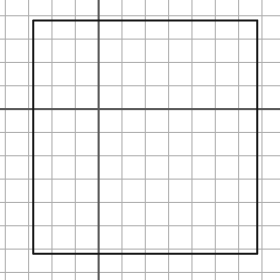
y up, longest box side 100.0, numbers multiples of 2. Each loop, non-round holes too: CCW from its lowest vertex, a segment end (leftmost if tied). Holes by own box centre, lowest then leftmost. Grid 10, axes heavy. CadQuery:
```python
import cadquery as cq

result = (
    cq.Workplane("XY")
    .moveTo(-28.0, -62.0)
    .lineTo(68.0, -62.0)
    .lineTo(68.0, 38.0)
    .lineTo(-28.0, 38.0)
    .close()
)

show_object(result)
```